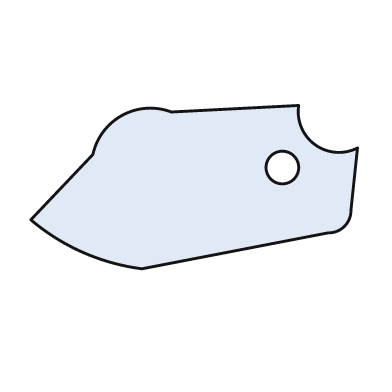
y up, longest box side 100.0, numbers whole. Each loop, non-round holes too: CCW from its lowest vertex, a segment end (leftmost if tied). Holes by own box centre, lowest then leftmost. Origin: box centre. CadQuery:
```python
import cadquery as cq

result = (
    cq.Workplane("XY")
    .moveTo(-16.0, -25.0)
    .lineTo(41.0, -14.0)
    .threePointArc((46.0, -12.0), (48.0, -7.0))
    .lineTo(50.0, 12.0)
    .threePointArc((37.0, 13.0), (32.0, 25.0))
    .lineTo(-7.0, 23.0)
    .threePointArc((-22.0, 22.0), (-31.0, 10.0))
    .lineTo(-50.0, -10.0)
    .threePointArc((-34.0, -20.0), (-16.0, -25.0))
    .close()
    .moveTo(27.0, 6.0)
    .circle(5.0)
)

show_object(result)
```